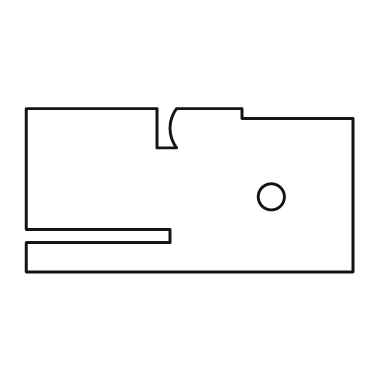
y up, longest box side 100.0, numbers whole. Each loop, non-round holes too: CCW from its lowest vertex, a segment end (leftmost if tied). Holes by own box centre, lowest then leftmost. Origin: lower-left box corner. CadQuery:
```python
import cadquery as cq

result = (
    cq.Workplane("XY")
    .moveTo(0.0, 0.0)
    .lineTo(100.0, 0.0)
    .lineTo(100.0, 47.0)
    .lineTo(66.0, 47.0)
    .lineTo(66.0, 50.0)
    .lineTo(46.0, 50.0)
    .threePointArc((44.0, 44.0), (46.0, 38.0))
    .lineTo(40.0, 38.0)
    .lineTo(40.0, 50.0)
    .lineTo(0.0, 50.0)
    .lineTo(0.0, 13.0)
    .lineTo(44.0, 13.0)
    .lineTo(44.0, 9.0)
    .lineTo(0.0, 9.0)
    .close()
    .moveTo(75.0, 23.0)
    .circle(4.0)
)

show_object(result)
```